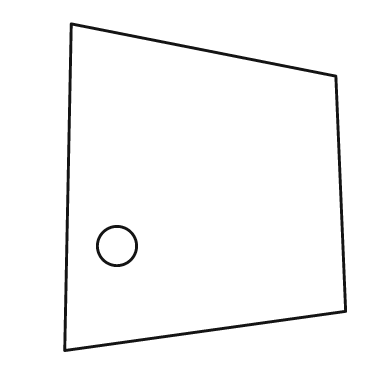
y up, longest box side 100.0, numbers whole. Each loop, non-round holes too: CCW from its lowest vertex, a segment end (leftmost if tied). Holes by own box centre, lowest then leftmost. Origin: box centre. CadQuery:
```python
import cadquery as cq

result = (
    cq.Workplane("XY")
    .moveTo(-43.0, -50.0)
    .lineTo(43.0, -38.0)
    .lineTo(40.0, 34.0)
    .lineTo(-41.0, 50.0)
    .close()
    .moveTo(-27.0, -18.0)
    .circle(6.0)
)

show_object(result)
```